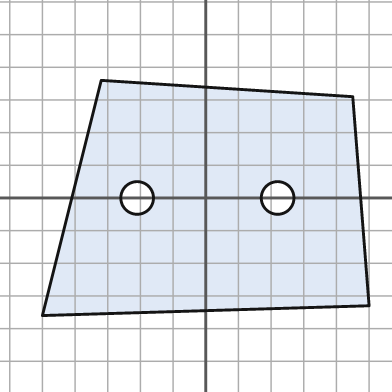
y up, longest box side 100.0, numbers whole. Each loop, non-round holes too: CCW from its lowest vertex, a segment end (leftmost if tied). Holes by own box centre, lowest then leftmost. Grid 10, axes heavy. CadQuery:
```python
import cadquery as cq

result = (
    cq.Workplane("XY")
    .moveTo(-50.0, -36.0)
    .lineTo(50.0, -33.0)
    .lineTo(45.0, 31.0)
    .lineTo(-32.0, 36.0)
    .close()
    .moveTo(-21.0, 0.0)
    .circle(5.0)
    .moveTo(22.0, 0.0)
    .circle(5.0)
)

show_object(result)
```